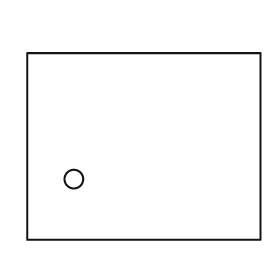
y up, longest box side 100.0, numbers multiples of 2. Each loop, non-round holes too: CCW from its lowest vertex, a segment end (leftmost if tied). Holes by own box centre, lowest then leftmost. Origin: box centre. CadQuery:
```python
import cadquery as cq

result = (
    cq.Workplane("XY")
    .moveTo(-50.0, -40.0)
    .lineTo(50.0, -40.0)
    .lineTo(50.0, 40.0)
    .lineTo(-50.0, 40.0)
    .close()
    .moveTo(-30.0, -14.0)
    .circle(4.0)
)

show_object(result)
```